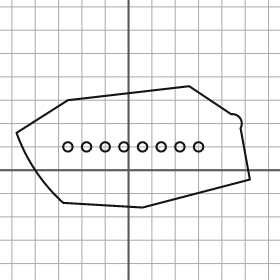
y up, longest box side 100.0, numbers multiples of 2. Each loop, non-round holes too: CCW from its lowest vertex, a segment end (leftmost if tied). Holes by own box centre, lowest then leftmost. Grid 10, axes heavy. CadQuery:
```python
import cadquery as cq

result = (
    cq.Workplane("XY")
    .moveTo(6.0, -16.0)
    .lineTo(52.0, -4.0)
    .lineTo(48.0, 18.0)
    .threePointArc((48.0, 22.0), (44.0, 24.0))
    .lineTo(26.0, 36.0)
    .lineTo(-26.0, 30.0)
    .lineTo(-48.0, 16.0)
    .threePointArc((-40.0, 0.0), (-28.0, -14.0))
    .close()
    .moveTo(-26.0, 10.0)
    .circle(2.0)
    .moveTo(-18.0, 10.0)
    .circle(2.0)
    .moveTo(-10.0, 10.0)
    .circle(2.0)
    .moveTo(-2.0, 10.0)
    .circle(2.0)
    .moveTo(6.0, 10.0)
    .circle(2.0)
    .moveTo(14.0, 10.0)
    .circle(2.0)
    .moveTo(22.0, 10.0)
    .circle(2.0)
    .moveTo(30.0, 10.0)
    .circle(2.0)
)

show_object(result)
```